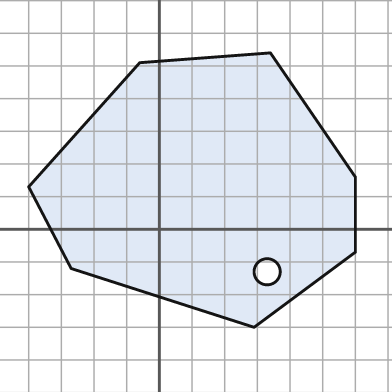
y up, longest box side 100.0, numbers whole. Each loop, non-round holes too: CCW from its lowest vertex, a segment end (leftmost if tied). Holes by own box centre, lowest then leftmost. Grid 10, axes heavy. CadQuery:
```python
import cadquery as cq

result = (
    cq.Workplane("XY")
    .moveTo(29.0, -30.0)
    .lineTo(60.0, -7.0)
    .lineTo(60.0, 16.0)
    .lineTo(34.0, 54.0)
    .lineTo(-6.0, 51.0)
    .lineTo(-40.0, 13.0)
    .lineTo(-27.0, -12.0)
    .close()
    .moveTo(33.0, -13.0)
    .circle(4.0)
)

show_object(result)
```